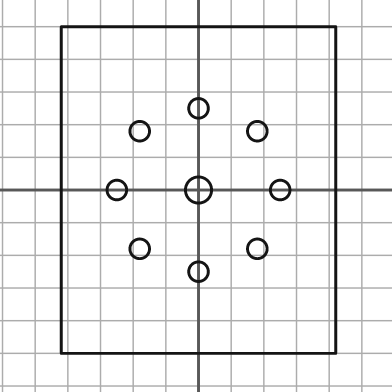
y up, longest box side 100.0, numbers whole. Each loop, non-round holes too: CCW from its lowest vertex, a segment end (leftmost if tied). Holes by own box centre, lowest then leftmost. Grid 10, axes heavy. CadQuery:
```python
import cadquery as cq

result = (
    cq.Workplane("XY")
    .moveTo(-42.0, -50.0)
    .lineTo(42.0, -50.0)
    .lineTo(42.0, 50.0)
    .lineTo(-42.0, 50.0)
    .close()
    .moveTo(0.0, -25.0)
    .circle(3.0)
    .moveTo(-18.0, -18.0)
    .circle(3.0)
    .moveTo(18.0, -18.0)
    .circle(3.0)
    .moveTo(-25.0, 0.0)
    .circle(3.0)
    .moveTo(0.0, 0.0)
    .circle(4.0)
    .moveTo(25.0, 0.0)
    .circle(3.0)
    .moveTo(-18.0, 18.0)
    .circle(3.0)
    .moveTo(18.0, 18.0)
    .circle(3.0)
    .moveTo(0.0, 25.0)
    .circle(3.0)
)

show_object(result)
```